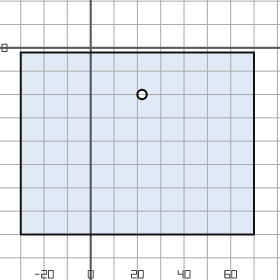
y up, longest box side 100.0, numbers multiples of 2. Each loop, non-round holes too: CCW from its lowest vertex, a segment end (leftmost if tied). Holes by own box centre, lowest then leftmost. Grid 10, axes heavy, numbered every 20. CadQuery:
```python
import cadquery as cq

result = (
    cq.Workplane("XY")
    .moveTo(-30.0, -80.0)
    .lineTo(70.0, -80.0)
    .lineTo(70.0, -2.0)
    .lineTo(-30.0, -2.0)
    .close()
    .moveTo(22.0, -20.0)
    .circle(2.0)
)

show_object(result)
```